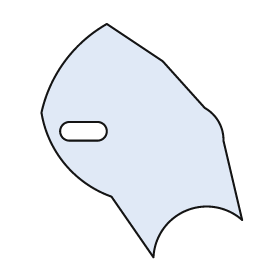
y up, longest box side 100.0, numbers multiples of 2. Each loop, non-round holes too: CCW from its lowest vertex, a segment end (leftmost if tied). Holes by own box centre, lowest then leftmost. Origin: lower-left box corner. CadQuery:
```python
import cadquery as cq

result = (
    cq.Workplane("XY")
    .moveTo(48.0, 0.0)
    .threePointArc((62.0, 20.0), (86.0, 16.0))
    .lineTo(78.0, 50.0)
    .threePointArc((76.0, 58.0), (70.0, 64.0))
    .lineTo(52.0, 84.0)
    .lineTo(28.0, 100.0)
    .threePointArc((10.0, 84.0), (0.0, 62.0))
    .threePointArc((10.0, 40.0), (30.0, 26.0))
    .close()
    .moveTo(12.0, 50.0)
    .lineTo(24.0, 50.0)
    .threePointArc((28.0, 54.0), (24.0, 58.0))
    .lineTo(12.0, 58.0)
    .threePointArc((8.0, 54.0), (12.0, 50.0))
    .close()
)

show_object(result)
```